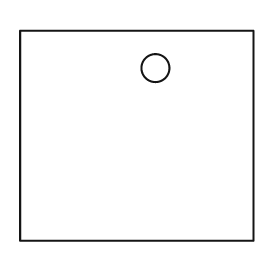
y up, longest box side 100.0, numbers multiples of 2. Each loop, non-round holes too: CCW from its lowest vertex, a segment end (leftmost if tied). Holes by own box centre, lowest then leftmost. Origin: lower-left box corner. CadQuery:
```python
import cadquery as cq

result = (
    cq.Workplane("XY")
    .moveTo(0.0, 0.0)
    .lineTo(100.0, 0.0)
    .lineTo(100.0, 90.0)
    .lineTo(0.0, 90.0)
    .close()
    .moveTo(58.0, 74.0)
    .circle(6.0)
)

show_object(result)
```